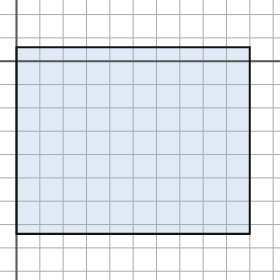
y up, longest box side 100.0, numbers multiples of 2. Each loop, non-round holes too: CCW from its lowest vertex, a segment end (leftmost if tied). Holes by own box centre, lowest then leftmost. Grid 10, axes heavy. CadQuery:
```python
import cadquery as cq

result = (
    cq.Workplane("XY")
    .moveTo(0.0, -74.0)
    .lineTo(100.0, -74.0)
    .lineTo(100.0, 6.0)
    .lineTo(0.0, 6.0)
    .close()
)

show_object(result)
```